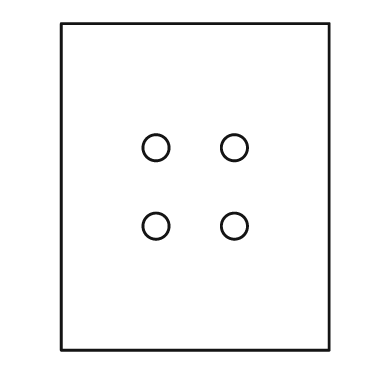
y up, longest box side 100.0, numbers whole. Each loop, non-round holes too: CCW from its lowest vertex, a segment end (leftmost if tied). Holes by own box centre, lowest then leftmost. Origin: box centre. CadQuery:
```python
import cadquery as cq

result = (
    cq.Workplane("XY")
    .moveTo(-41.0, -50.0)
    .lineTo(41.0, -50.0)
    .lineTo(41.0, 50.0)
    .lineTo(-41.0, 50.0)
    .close()
    .moveTo(-12.0, -12.0)
    .circle(4.0)
    .moveTo(12.0, -12.0)
    .circle(4.0)
    .moveTo(-12.0, 12.0)
    .circle(4.0)
    .moveTo(12.0, 12.0)
    .circle(4.0)
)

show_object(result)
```